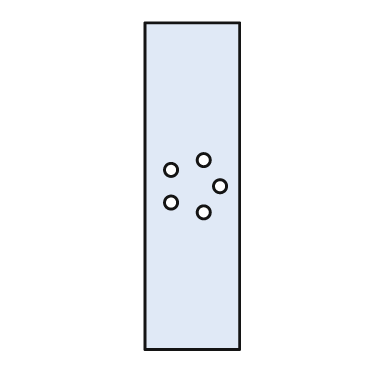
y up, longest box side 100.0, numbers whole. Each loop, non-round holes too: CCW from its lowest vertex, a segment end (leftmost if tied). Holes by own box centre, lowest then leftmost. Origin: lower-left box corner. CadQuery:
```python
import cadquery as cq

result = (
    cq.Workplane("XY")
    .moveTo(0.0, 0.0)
    .lineTo(29.0, 0.0)
    .lineTo(29.0, 100.0)
    .lineTo(0.0, 100.0)
    .close()
    .moveTo(18.0, 42.0)
    .circle(2.0)
    .moveTo(8.0, 45.0)
    .circle(2.0)
    .moveTo(23.0, 50.0)
    .circle(2.0)
    .moveTo(8.0, 55.0)
    .circle(2.0)
    .moveTo(18.0, 58.0)
    .circle(2.0)
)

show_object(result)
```